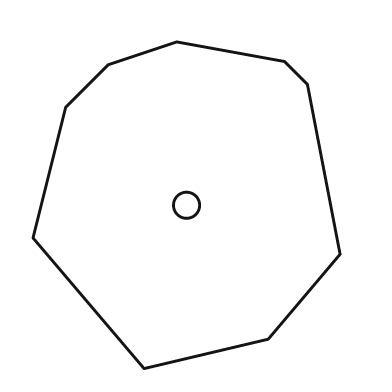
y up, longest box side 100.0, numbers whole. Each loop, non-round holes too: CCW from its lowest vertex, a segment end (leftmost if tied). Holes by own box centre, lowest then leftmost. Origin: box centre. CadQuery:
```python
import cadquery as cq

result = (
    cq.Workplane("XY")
    .moveTo(-13.0, -50.0)
    .lineTo(25.0, -41.0)
    .lineTo(47.0, -15.0)
    .lineTo(37.0, 37.0)
    .lineTo(30.0, 44.0)
    .lineTo(-3.0, 50.0)
    .lineTo(-24.0, 43.0)
    .lineTo(-37.0, 30.0)
    .lineTo(-47.0, -10.0)
    .close()
    .moveTo(0.0, 0.0)
    .circle(4.0)
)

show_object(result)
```